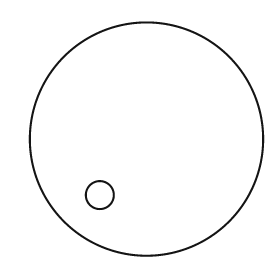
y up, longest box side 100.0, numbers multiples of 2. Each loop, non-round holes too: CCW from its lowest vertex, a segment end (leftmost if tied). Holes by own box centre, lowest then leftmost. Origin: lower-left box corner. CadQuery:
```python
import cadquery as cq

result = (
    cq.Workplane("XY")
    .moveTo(50.0, 50.0)
    .circle(50.0)
    .moveTo(30.0, 26.0)
    .circle(6.0)
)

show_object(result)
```